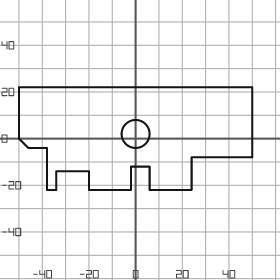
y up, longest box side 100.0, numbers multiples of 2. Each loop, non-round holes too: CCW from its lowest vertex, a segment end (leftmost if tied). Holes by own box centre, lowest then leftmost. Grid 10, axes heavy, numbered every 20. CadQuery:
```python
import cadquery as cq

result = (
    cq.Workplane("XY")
    .moveTo(-38.0, -22.0)
    .lineTo(-34.0, -22.0)
    .lineTo(-34.0, -14.0)
    .lineTo(-20.0, -14.0)
    .lineTo(-20.0, -22.0)
    .lineTo(-2.0, -22.0)
    .lineTo(-2.0, -12.0)
    .lineTo(6.0, -12.0)
    .lineTo(6.0, -22.0)
    .lineTo(24.0, -22.0)
    .lineTo(24.0, -8.0)
    .lineTo(50.0, -8.0)
    .lineTo(50.0, 22.0)
    .lineTo(-50.0, 22.0)
    .lineTo(-50.0, 0.0)
    .lineTo(-46.0, -4.0)
    .lineTo(-38.0, -4.0)
    .close()
    .moveTo(0.0, 2.0)
    .circle(6.0)
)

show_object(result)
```